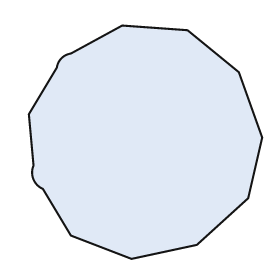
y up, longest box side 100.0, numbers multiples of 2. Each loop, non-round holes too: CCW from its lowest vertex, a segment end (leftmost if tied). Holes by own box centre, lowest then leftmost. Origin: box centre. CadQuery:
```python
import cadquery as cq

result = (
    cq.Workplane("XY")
    .moveTo(-6.0, -50.0)
    .lineTo(22.0, -44.0)
    .lineTo(44.0, -24.0)
    .lineTo(50.0, 2.0)
    .lineTo(40.0, 30.0)
    .lineTo(18.0, 48.0)
    .lineTo(-10.0, 50.0)
    .lineTo(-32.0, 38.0)
    .threePointArc((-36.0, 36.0), (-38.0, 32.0))
    .lineTo(-50.0, 12.0)
    .lineTo(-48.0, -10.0)
    .threePointArc((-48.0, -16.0), (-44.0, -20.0))
    .lineTo(-32.0, -40.0)
    .close()
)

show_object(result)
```